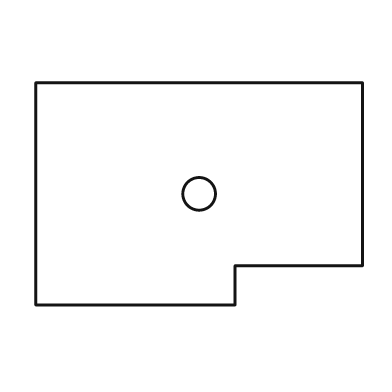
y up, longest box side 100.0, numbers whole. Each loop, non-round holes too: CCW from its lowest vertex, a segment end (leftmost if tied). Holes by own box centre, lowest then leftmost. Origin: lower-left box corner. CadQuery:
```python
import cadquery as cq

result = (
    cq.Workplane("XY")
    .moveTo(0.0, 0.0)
    .lineTo(61.0, 0.0)
    .lineTo(61.0, 12.0)
    .lineTo(100.0, 12.0)
    .lineTo(100.0, 68.0)
    .lineTo(0.0, 68.0)
    .close()
    .moveTo(50.0, 34.0)
    .circle(5.0)
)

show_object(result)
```